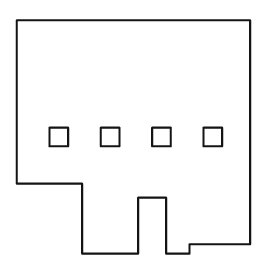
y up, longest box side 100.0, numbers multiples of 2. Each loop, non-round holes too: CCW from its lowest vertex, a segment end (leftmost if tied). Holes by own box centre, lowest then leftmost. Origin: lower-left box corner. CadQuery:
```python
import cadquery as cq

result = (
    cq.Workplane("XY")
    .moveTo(28.0, 0.0)
    .lineTo(52.0, 0.0)
    .lineTo(52.0, 24.0)
    .lineTo(64.0, 24.0)
    .lineTo(64.0, 0.0)
    .lineTo(74.0, 0.0)
    .lineTo(74.0, 4.0)
    .lineTo(100.0, 4.0)
    .lineTo(100.0, 100.0)
    .lineTo(0.0, 100.0)
    .lineTo(0.0, 30.0)
    .lineTo(28.0, 30.0)
    .close()
    .moveTo(14.0, 46.0)
    .lineTo(22.0, 46.0)
    .lineTo(22.0, 54.0)
    .lineTo(14.0, 54.0)
    .close()
    .moveTo(36.0, 46.0)
    .lineTo(44.0, 46.0)
    .lineTo(44.0, 54.0)
    .lineTo(36.0, 54.0)
    .close()
    .moveTo(58.0, 46.0)
    .lineTo(66.0, 46.0)
    .lineTo(66.0, 54.0)
    .lineTo(58.0, 54.0)
    .close()
    .moveTo(80.0, 46.0)
    .lineTo(88.0, 46.0)
    .lineTo(88.0, 54.0)
    .lineTo(80.0, 54.0)
    .close()
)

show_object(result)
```